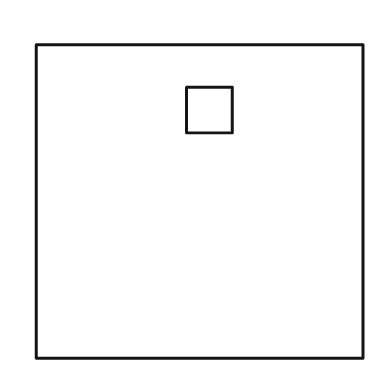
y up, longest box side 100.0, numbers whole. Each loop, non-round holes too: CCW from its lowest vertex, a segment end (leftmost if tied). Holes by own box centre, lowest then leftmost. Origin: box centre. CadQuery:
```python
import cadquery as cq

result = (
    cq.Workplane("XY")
    .moveTo(-50.0, -48.0)
    .lineTo(50.0, -48.0)
    .lineTo(50.0, 48.0)
    .lineTo(-50.0, 48.0)
    .close()
    .moveTo(-4.0, 21.0)
    .lineTo(10.0, 21.0)
    .lineTo(10.0, 35.0)
    .lineTo(-4.0, 35.0)
    .close()
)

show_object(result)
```